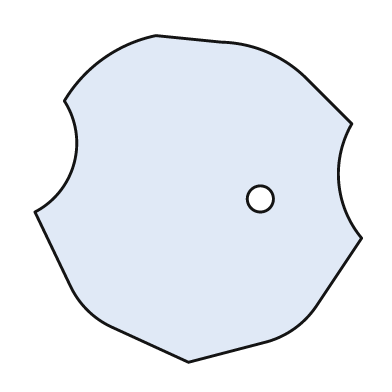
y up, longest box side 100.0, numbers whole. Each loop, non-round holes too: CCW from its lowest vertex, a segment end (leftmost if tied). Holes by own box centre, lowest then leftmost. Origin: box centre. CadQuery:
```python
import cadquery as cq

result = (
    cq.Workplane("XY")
    .moveTo(-3.0, -50.0)
    .lineTo(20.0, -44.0)
    .threePointArc((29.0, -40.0), (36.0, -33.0))
    .lineTo(50.0, -12.0)
    .threePointArc((43.0, 5.0), (47.0, 23.0))
    .lineTo(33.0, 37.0)
    .threePointArc((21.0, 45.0), (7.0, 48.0))
    .lineTo(-13.0, 50.0)
    .threePointArc((-29.0, 43.0), (-41.0, 30.0))
    .threePointArc((-38.0, 11.0), (-50.0, -4.0))
    .lineTo(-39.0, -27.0)
    .threePointArc((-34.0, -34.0), (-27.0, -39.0))
    .close()
    .moveTo(19.0, 0.0)
    .circle(4.0)
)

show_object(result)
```